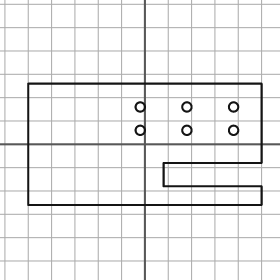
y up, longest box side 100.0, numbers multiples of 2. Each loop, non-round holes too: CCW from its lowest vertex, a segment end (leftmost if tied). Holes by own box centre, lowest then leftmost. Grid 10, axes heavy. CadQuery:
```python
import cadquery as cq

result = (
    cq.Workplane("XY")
    .moveTo(-50.0, -26.0)
    .lineTo(50.0, -26.0)
    .lineTo(50.0, -18.0)
    .lineTo(8.0, -18.0)
    .lineTo(8.0, -8.0)
    .lineTo(50.0, -8.0)
    .lineTo(50.0, 26.0)
    .lineTo(-50.0, 26.0)
    .close()
    .moveTo(-2.0, 6.0)
    .circle(2.0)
    .moveTo(18.0, 6.0)
    .circle(2.0)
    .moveTo(38.0, 6.0)
    .circle(2.0)
    .moveTo(-2.0, 16.0)
    .circle(2.0)
    .moveTo(18.0, 16.0)
    .circle(2.0)
    .moveTo(38.0, 16.0)
    .circle(2.0)
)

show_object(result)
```